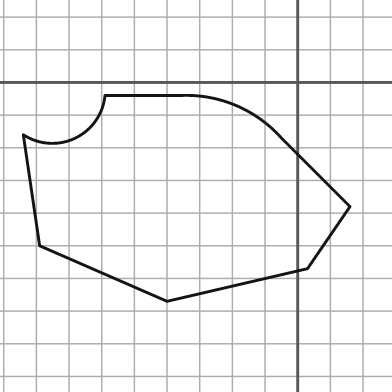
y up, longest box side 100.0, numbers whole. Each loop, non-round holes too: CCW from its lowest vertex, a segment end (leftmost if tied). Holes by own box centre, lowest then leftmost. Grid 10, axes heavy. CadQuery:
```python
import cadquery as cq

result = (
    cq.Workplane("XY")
    .moveTo(-40.0, -67.0)
    .lineTo(3.0, -57.0)
    .lineTo(16.0, -38.0)
    .lineTo(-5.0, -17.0)
    .threePointArc((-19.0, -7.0), (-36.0, -4.0))
    .lineTo(-59.0, -4.0)
    .threePointArc((-68.0, -17.0), (-84.0, -16.0))
    .lineTo(-79.0, -50.0)
    .close()
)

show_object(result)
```